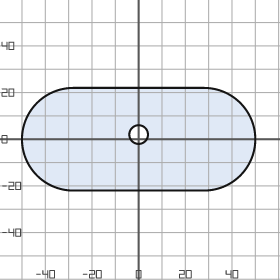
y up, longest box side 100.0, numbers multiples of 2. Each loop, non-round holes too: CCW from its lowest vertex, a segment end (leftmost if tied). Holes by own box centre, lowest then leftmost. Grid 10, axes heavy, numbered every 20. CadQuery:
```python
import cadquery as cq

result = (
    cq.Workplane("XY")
    .moveTo(-28.0, -22.0)
    .lineTo(28.0, -22.0)
    .threePointArc((50.0, 0.0), (28.0, 22.0))
    .lineTo(-28.0, 22.0)
    .threePointArc((-50.0, 0.0), (-28.0, -22.0))
    .close()
    .moveTo(0.0, 2.0)
    .circle(4.0)
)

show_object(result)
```